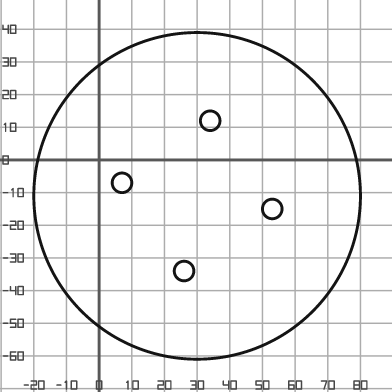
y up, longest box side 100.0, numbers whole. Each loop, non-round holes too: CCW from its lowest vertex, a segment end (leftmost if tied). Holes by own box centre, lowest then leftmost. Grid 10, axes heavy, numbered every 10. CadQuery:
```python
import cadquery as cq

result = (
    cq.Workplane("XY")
    .moveTo(30.0, -11.0)
    .circle(50.0)
    .moveTo(26.0, -34.0)
    .circle(3.0)
    .moveTo(53.0, -15.0)
    .circle(3.0)
    .moveTo(7.0, -7.0)
    .circle(3.0)
    .moveTo(34.0, 12.0)
    .circle(3.0)
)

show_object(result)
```